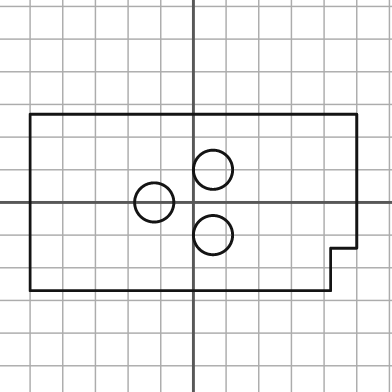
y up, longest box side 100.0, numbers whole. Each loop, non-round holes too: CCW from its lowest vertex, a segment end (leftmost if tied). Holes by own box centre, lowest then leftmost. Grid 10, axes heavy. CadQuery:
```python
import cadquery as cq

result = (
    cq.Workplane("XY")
    .moveTo(-50.0, -27.0)
    .lineTo(42.0, -27.0)
    .lineTo(42.0, -14.0)
    .lineTo(50.0, -14.0)
    .lineTo(50.0, 27.0)
    .lineTo(-50.0, 27.0)
    .close()
    .moveTo(6.0, -10.0)
    .circle(6.0)
    .moveTo(-12.0, 0.0)
    .circle(6.0)
    .moveTo(6.0, 10.0)
    .circle(6.0)
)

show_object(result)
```